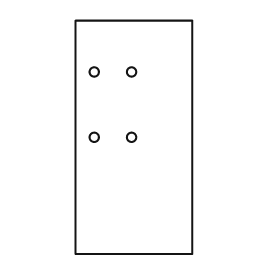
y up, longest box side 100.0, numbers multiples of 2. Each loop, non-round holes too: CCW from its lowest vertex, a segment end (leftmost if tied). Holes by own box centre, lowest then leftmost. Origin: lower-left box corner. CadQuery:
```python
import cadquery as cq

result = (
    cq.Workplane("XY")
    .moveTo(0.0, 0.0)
    .lineTo(50.0, 0.0)
    .lineTo(50.0, 100.0)
    .lineTo(0.0, 100.0)
    .close()
    .moveTo(8.0, 50.0)
    .circle(2.0)
    .moveTo(24.0, 50.0)
    .circle(2.0)
    .moveTo(8.0, 78.0)
    .circle(2.0)
    .moveTo(24.0, 78.0)
    .circle(2.0)
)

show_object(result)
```